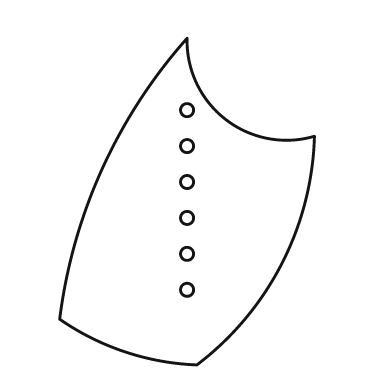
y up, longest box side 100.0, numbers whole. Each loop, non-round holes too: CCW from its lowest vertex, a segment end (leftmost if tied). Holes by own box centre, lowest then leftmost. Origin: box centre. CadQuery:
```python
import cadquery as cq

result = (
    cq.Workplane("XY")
    .moveTo(3.0, -50.0)
    .threePointArc((29.0, -19.0), (39.0, 20.0))
    .threePointArc((12.0, 25.0), (0.0, 50.0))
    .threePointArc((-26.0, 10.0), (-39.0, -36.0))
    .threePointArc((-19.0, -46.0), (3.0, -50.0))
    .close()
    .moveTo(0.0, -27.0)
    .circle(2.0)
    .moveTo(0.0, -16.0)
    .circle(2.0)
    .moveTo(0.0, -5.0)
    .circle(2.0)
    .moveTo(0.0, 6.0)
    .circle(2.0)
    .moveTo(0.0, 17.0)
    .circle(2.0)
    .moveTo(0.0, 28.0)
    .circle(2.0)
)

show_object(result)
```